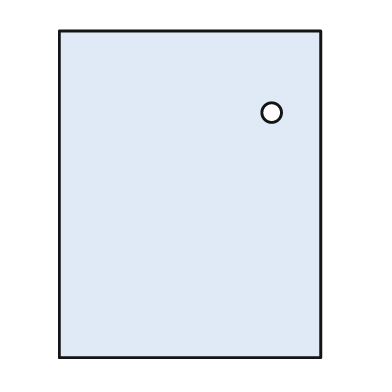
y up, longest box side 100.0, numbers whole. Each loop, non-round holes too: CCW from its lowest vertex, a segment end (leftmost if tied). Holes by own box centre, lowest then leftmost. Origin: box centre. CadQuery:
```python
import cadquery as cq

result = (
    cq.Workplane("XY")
    .moveTo(-40.0, -50.0)
    .lineTo(40.0, -50.0)
    .lineTo(40.0, 50.0)
    .lineTo(-40.0, 50.0)
    .close()
    .moveTo(25.0, 25.0)
    .circle(3.0)
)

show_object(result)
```